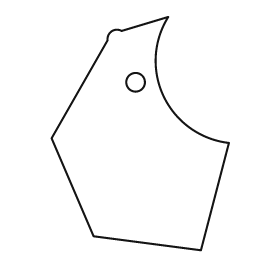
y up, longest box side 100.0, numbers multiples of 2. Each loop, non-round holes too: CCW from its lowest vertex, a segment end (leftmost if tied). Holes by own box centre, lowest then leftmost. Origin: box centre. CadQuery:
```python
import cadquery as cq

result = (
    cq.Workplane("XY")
    .moveTo(26.0, -50.0)
    .lineTo(38.0, -4.0)
    .threePointArc((10.0, 16.0), (12.0, 50.0))
    .lineTo(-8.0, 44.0)
    .threePointArc((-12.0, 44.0), (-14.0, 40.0))
    .lineTo(-38.0, -2.0)
    .lineTo(-20.0, -44.0)
    .close()
    .moveTo(-2.0, 22.0)
    .circle(4.0)
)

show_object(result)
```